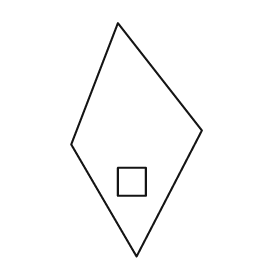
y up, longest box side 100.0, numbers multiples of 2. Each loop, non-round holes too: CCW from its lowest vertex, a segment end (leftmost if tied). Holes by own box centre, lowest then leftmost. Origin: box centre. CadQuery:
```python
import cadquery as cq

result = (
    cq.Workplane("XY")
    .moveTo(0.0, -50.0)
    .lineTo(28.0, 4.0)
    .lineTo(-8.0, 50.0)
    .lineTo(-28.0, -2.0)
    .close()
    .moveTo(-8.0, -24.0)
    .lineTo(4.0, -24.0)
    .lineTo(4.0, -12.0)
    .lineTo(-8.0, -12.0)
    .close()
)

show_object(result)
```